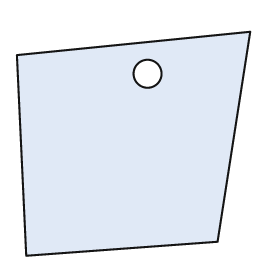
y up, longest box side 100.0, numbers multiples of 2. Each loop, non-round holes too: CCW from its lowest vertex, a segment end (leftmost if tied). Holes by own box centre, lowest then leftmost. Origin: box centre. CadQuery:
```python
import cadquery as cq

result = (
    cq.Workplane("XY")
    .moveTo(-46.0, -48.0)
    .lineTo(36.0, -42.0)
    .lineTo(50.0, 48.0)
    .lineTo(-50.0, 38.0)
    .close()
    .moveTo(6.0, 30.0)
    .circle(6.0)
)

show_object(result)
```